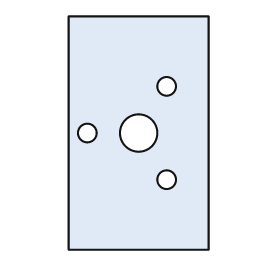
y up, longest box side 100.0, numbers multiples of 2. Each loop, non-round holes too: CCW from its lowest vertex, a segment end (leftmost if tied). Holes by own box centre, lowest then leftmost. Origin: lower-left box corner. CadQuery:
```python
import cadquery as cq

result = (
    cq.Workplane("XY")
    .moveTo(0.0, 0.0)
    .lineTo(60.0, 0.0)
    .lineTo(60.0, 100.0)
    .lineTo(0.0, 100.0)
    .close()
    .moveTo(42.0, 30.0)
    .circle(4.0)
    .moveTo(8.0, 50.0)
    .circle(4.0)
    .moveTo(30.0, 50.0)
    .circle(8.0)
    .moveTo(42.0, 70.0)
    .circle(4.0)
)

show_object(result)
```